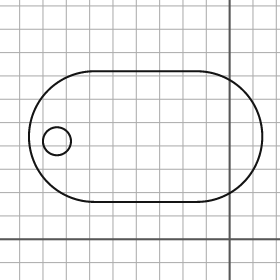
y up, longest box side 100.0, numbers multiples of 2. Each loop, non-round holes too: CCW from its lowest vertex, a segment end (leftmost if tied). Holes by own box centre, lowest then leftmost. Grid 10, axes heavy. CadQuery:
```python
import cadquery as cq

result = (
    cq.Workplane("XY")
    .moveTo(-58.0, 16.0)
    .lineTo(-14.0, 16.0)
    .threePointArc((14.0, 44.0), (-14.0, 72.0))
    .lineTo(-58.0, 72.0)
    .threePointArc((-86.0, 44.0), (-58.0, 16.0))
    .close()
    .moveTo(-74.0, 42.0)
    .circle(6.0)
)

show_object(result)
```